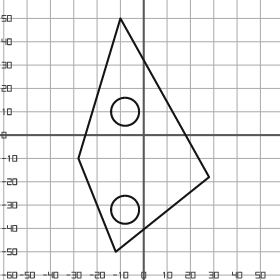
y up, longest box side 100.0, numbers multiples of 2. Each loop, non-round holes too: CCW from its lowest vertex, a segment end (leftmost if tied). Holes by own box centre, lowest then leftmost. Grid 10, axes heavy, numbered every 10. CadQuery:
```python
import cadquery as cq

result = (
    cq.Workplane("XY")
    .moveTo(-12.0, -50.0)
    .lineTo(28.0, -18.0)
    .lineTo(-10.0, 50.0)
    .lineTo(-28.0, -10.0)
    .close()
    .moveTo(-8.0, -32.0)
    .circle(6.0)
    .moveTo(-8.0, 10.0)
    .circle(6.0)
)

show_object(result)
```